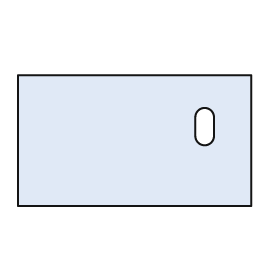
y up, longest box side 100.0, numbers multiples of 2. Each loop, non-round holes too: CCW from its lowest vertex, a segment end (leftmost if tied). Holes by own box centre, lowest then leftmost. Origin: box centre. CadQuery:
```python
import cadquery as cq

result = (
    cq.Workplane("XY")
    .moveTo(-50.0, -28.0)
    .lineTo(50.0, -28.0)
    .lineTo(50.0, 28.0)
    .lineTo(-50.0, 28.0)
    .close()
    .moveTo(26.0, 2.0)
    .threePointArc((30.0, -2.0), (34.0, 2.0))
    .lineTo(34.0, 10.0)
    .threePointArc((30.0, 14.0), (26.0, 10.0))
    .close()
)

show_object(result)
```